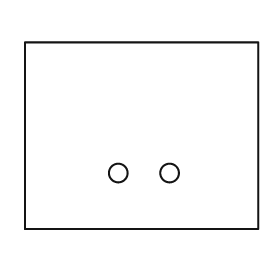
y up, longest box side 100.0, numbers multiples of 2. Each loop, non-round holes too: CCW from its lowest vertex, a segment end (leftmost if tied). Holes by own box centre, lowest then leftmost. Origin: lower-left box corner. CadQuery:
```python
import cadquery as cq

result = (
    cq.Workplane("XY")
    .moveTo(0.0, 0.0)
    .lineTo(100.0, 0.0)
    .lineTo(100.0, 80.0)
    .lineTo(0.0, 80.0)
    .close()
    .moveTo(40.0, 24.0)
    .circle(4.0)
    .moveTo(62.0, 24.0)
    .circle(4.0)
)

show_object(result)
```